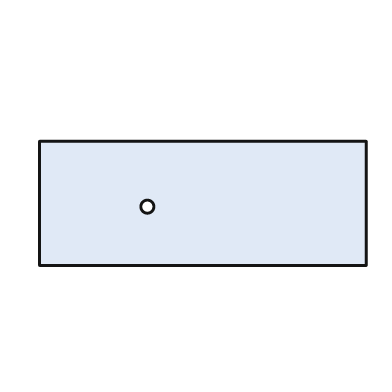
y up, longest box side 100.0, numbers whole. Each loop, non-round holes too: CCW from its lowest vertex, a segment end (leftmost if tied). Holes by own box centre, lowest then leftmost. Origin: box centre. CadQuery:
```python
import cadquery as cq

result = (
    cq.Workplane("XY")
    .moveTo(-50.0, -19.0)
    .lineTo(50.0, -19.0)
    .lineTo(50.0, 19.0)
    .lineTo(-50.0, 19.0)
    .close()
    .moveTo(-17.0, -1.0)
    .circle(2.0)
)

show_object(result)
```